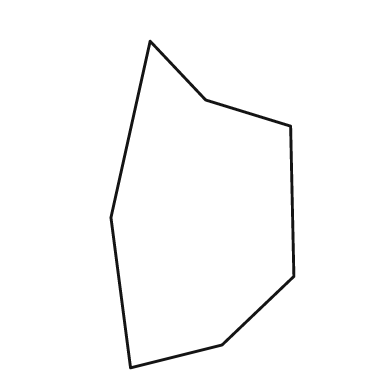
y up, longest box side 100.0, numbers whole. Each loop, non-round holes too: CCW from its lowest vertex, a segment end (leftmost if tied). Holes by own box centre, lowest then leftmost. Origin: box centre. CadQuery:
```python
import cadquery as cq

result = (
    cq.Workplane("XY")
    .moveTo(-22.0, -50.0)
    .lineTo(6.0, -43.0)
    .lineTo(28.0, -22.0)
    .lineTo(27.0, 24.0)
    .lineTo(1.0, 32.0)
    .lineTo(-16.0, 50.0)
    .lineTo(-28.0, -4.0)
    .close()
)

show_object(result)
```